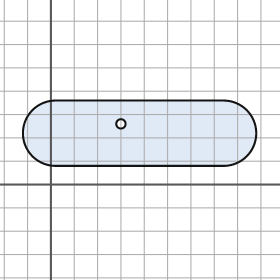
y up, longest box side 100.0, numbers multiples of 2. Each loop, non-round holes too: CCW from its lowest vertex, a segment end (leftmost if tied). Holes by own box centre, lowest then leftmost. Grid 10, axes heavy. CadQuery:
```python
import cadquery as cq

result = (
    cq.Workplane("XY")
    .moveTo(2.0, 8.0)
    .lineTo(74.0, 8.0)
    .threePointArc((88.0, 22.0), (74.0, 36.0))
    .lineTo(2.0, 36.0)
    .threePointArc((-12.0, 22.0), (2.0, 8.0))
    .close()
    .moveTo(30.0, 26.0)
    .circle(2.0)
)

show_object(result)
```